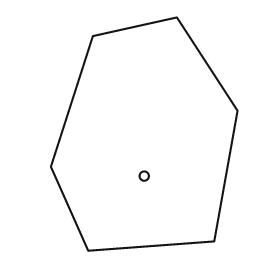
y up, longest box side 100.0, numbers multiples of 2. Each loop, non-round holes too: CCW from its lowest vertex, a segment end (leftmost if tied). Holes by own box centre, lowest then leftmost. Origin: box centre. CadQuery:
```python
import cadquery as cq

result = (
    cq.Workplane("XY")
    .moveTo(-24.0, -50.0)
    .lineTo(30.0, -46.0)
    .lineTo(40.0, 10.0)
    .lineTo(14.0, 50.0)
    .lineTo(-22.0, 42.0)
    .lineTo(-40.0, -14.0)
    .close()
    .moveTo(0.0, -18.0)
    .circle(2.0)
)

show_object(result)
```